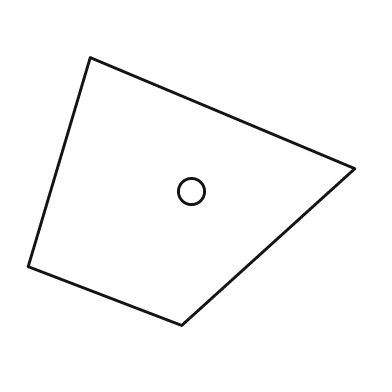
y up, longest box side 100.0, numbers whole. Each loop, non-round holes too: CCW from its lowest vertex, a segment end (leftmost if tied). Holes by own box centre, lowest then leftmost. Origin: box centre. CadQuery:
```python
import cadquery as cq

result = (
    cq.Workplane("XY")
    .moveTo(-3.0, -41.0)
    .lineTo(50.0, 7.0)
    .lineTo(-31.0, 41.0)
    .lineTo(-50.0, -23.0)
    .close()
    .moveTo(0.0, 0.0)
    .circle(4.0)
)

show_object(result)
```